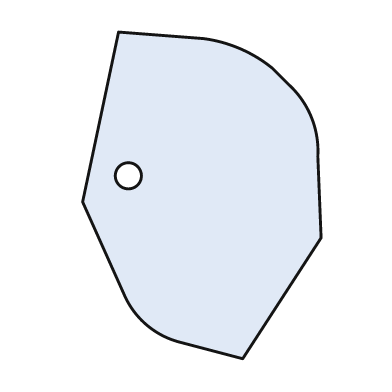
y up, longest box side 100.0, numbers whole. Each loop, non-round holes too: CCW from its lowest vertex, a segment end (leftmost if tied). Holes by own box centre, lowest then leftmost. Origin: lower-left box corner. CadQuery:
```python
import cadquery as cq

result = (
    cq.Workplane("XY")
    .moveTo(49.0, 0.0)
    .lineTo(73.0, 37.0)
    .lineTo(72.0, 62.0)
    .threePointArc((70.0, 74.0), (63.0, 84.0))
    .lineTo(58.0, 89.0)
    .threePointArc((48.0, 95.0), (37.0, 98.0))
    .lineTo(11.0, 100.0)
    .lineTo(0.0, 48.0)
    .lineTo(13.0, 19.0)
    .threePointArc((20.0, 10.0), (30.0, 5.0))
    .close()
    .moveTo(14.0, 56.0)
    .circle(4.0)
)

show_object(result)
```